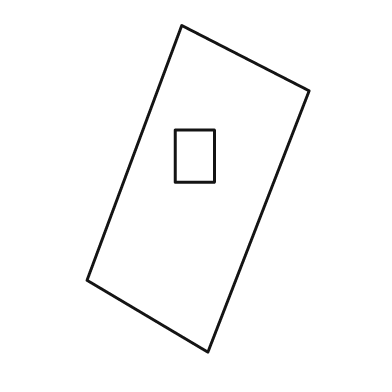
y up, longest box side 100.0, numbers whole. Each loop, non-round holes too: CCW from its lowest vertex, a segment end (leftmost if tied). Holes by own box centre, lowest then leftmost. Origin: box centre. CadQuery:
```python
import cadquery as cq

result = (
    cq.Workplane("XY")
    .moveTo(3.0, -50.0)
    .lineTo(34.0, 30.0)
    .lineTo(-5.0, 50.0)
    .lineTo(-34.0, -28.0)
    .close()
    .moveTo(-7.0, 2.0)
    .lineTo(5.0, 2.0)
    .lineTo(5.0, 18.0)
    .lineTo(-7.0, 18.0)
    .close()
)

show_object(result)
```